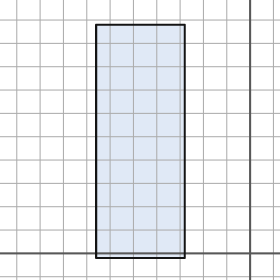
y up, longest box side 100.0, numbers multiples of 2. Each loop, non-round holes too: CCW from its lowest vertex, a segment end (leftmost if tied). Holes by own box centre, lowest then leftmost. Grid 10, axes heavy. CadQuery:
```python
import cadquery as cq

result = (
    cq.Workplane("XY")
    .moveTo(-66.0, -2.0)
    .lineTo(-28.0, -2.0)
    .lineTo(-28.0, 98.0)
    .lineTo(-66.0, 98.0)
    .close()
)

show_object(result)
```